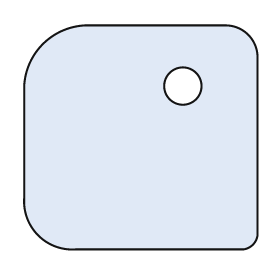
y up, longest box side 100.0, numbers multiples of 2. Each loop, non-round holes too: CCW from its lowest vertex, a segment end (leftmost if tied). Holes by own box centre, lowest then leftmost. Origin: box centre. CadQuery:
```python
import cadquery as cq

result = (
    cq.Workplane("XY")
    .moveTo(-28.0, -48.0)
    .lineTo(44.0, -48.0)
    .threePointArc((48.0, -46.0), (50.0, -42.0))
    .lineTo(50.0, 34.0)
    .threePointArc((46.0, 44.0), (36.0, 48.0))
    .lineTo(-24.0, 48.0)
    .threePointArc((-42.0, 40.0), (-50.0, 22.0))
    .lineTo(-50.0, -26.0)
    .threePointArc((-44.0, -42.0), (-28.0, -48.0))
    .close()
    .moveTo(18.0, 22.0)
    .circle(8.0)
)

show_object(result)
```